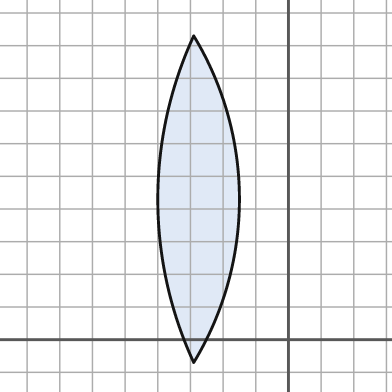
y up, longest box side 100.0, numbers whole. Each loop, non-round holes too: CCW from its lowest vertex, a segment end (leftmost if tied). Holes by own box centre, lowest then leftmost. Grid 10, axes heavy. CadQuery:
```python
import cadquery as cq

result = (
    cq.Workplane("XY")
    .moveTo(-29.0, -7.0)
    .threePointArc((-15.0, 43.0), (-29.0, 93.0))
    .threePointArc((-40.0, 43.0), (-29.0, -7.0))
    .close()
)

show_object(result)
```